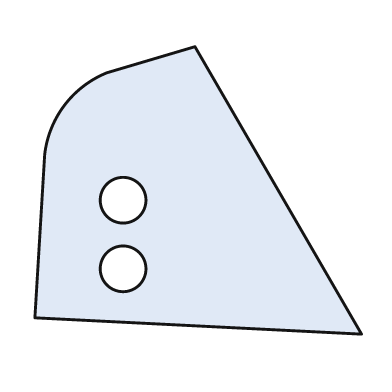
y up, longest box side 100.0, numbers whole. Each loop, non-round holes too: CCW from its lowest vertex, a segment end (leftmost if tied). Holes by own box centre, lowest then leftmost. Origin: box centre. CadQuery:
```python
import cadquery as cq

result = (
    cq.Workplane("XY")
    .moveTo(50.0, -44.0)
    .lineTo(-1.0, 44.0)
    .lineTo(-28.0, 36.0)
    .threePointArc((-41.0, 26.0), (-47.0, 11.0))
    .lineTo(-50.0, -39.0)
    .close()
    .moveTo(-23.0, -24.0)
    .circle(7.0)
    .moveTo(-23.0, -3.0)
    .circle(7.0)
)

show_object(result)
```